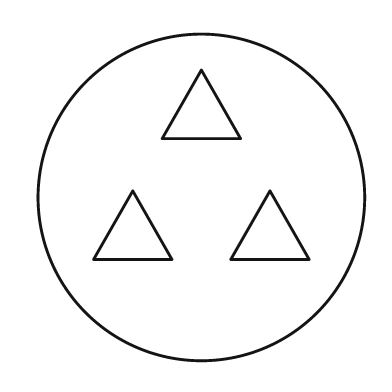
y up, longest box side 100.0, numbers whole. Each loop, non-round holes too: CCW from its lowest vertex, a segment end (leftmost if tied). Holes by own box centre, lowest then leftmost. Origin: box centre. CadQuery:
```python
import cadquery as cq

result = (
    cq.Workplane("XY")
    .moveTo(0.0, 0.0)
    .circle(50.0)
    .moveTo(-33.0, -19.0)
    .lineTo(-9.0, -19.0)
    .lineTo(-21.0, 2.0)
    .close()
    .moveTo(9.0, -19.0)
    .lineTo(33.0, -19.0)
    .lineTo(21.0, 2.0)
    .close()
    .moveTo(-12.0, 18.0)
    .lineTo(12.0, 18.0)
    .lineTo(0.0, 39.0)
    .close()
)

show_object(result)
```